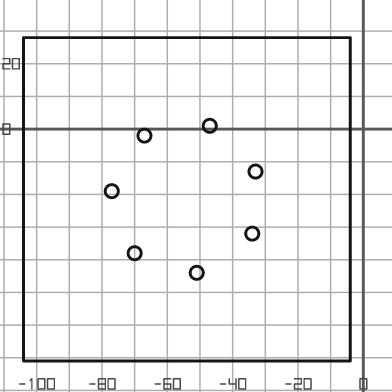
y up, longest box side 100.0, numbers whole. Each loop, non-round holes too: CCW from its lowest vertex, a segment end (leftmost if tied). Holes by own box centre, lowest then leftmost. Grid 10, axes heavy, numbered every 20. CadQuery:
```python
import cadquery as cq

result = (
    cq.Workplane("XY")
    .moveTo(-104.0, -71.0)
    .lineTo(-4.0, -71.0)
    .lineTo(-4.0, 28.0)
    .lineTo(-104.0, 28.0)
    .close()
    .moveTo(-51.0, -44.0)
    .circle(2.0)
    .moveTo(-70.0, -38.0)
    .circle(2.0)
    .moveTo(-34.0, -32.0)
    .circle(2.0)
    .moveTo(-77.0, -19.0)
    .circle(2.0)
    .moveTo(-33.0, -13.0)
    .circle(2.0)
    .moveTo(-67.0, -2.0)
    .circle(2.0)
    .moveTo(-47.0, 1.0)
    .circle(2.0)
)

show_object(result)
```